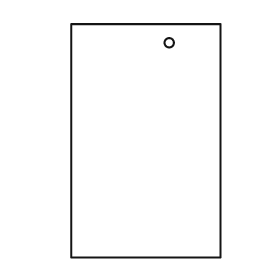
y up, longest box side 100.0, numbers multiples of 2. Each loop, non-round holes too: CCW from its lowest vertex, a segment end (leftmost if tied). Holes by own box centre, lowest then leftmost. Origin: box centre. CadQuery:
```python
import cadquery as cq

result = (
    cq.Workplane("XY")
    .moveTo(-32.0, -50.0)
    .lineTo(32.0, -50.0)
    .lineTo(32.0, 50.0)
    .lineTo(-32.0, 50.0)
    .close()
    .moveTo(10.0, 42.0)
    .circle(2.0)
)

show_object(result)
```